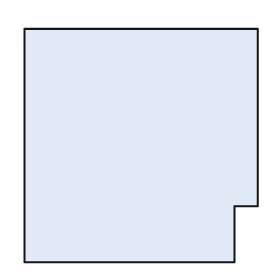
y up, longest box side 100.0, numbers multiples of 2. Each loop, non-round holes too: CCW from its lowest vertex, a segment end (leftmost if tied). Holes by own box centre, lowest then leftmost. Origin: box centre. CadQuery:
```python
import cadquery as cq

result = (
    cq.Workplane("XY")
    .moveTo(-50.0, -50.0)
    .lineTo(40.0, -50.0)
    .lineTo(40.0, -26.0)
    .lineTo(50.0, -26.0)
    .lineTo(50.0, 50.0)
    .lineTo(-50.0, 50.0)
    .close()
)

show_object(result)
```